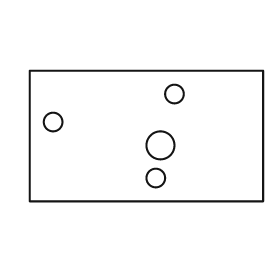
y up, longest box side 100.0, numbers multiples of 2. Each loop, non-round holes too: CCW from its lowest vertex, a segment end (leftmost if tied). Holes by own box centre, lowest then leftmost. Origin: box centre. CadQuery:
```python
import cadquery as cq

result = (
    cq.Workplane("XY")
    .moveTo(-50.0, -28.0)
    .lineTo(50.0, -28.0)
    .lineTo(50.0, 28.0)
    .lineTo(-50.0, 28.0)
    .close()
    .moveTo(4.0, -18.0)
    .circle(4.0)
    .moveTo(6.0, -4.0)
    .circle(6.0)
    .moveTo(-40.0, 6.0)
    .circle(4.0)
    .moveTo(12.0, 18.0)
    .circle(4.0)
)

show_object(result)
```